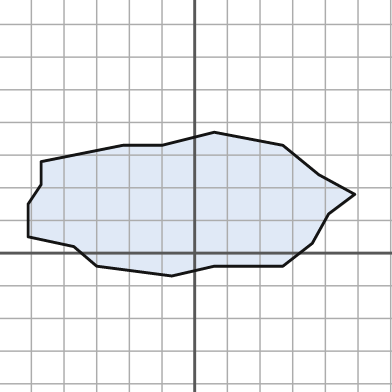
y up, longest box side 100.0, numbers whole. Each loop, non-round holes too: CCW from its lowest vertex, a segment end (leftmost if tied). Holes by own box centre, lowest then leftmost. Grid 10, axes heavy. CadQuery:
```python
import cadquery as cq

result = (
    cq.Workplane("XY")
    .moveTo(-7.0, -7.0)
    .lineTo(6.0, -4.0)
    .lineTo(27.0, -4.0)
    .lineTo(36.0, 3.0)
    .lineTo(41.0, 12.0)
    .lineTo(49.0, 18.0)
    .lineTo(38.0, 24.0)
    .lineTo(27.0, 33.0)
    .lineTo(6.0, 37.0)
    .lineTo(-10.0, 33.0)
    .lineTo(-22.0, 33.0)
    .lineTo(-47.0, 28.0)
    .lineTo(-47.0, 21.0)
    .lineTo(-51.0, 15.0)
    .lineTo(-51.0, 5.0)
    .lineTo(-37.0, 2.0)
    .lineTo(-30.0, -4.0)
    .close()
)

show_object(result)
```